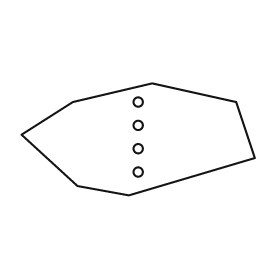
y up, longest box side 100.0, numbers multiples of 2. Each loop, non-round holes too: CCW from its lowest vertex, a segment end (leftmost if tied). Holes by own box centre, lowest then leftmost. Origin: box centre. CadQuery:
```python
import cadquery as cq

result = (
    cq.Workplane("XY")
    .moveTo(-4.0, -24.0)
    .lineTo(50.0, -8.0)
    .lineTo(42.0, 16.0)
    .lineTo(6.0, 24.0)
    .lineTo(-28.0, 16.0)
    .lineTo(-50.0, 2.0)
    .lineTo(-26.0, -20.0)
    .close()
    .moveTo(0.0, -14.0)
    .circle(2.0)
    .moveTo(0.0, -4.0)
    .circle(2.0)
    .moveTo(0.0, 6.0)
    .circle(2.0)
    .moveTo(0.0, 16.0)
    .circle(2.0)
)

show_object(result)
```